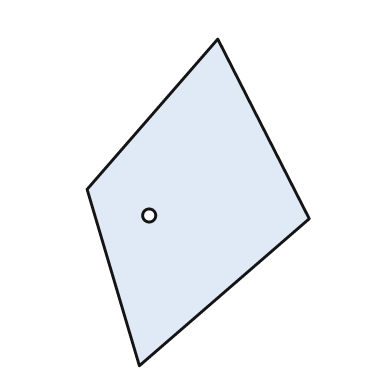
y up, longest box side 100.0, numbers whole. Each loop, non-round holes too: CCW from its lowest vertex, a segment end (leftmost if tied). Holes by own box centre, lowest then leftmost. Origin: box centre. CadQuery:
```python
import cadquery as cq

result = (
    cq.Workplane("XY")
    .moveTo(-18.0, -50.0)
    .lineTo(34.0, -5.0)
    .lineTo(6.0, 50.0)
    .lineTo(-34.0, 4.0)
    .close()
    .moveTo(-15.0, -4.0)
    .circle(2.0)
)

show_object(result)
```